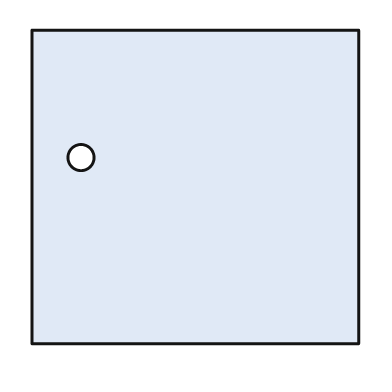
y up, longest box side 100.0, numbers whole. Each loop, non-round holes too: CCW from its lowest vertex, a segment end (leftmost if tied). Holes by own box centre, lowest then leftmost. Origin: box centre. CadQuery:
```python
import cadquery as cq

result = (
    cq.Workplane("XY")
    .moveTo(-50.0, -48.0)
    .lineTo(50.0, -48.0)
    .lineTo(50.0, 48.0)
    .lineTo(-50.0, 48.0)
    .close()
    .moveTo(-35.0, 9.0)
    .circle(4.0)
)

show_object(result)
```